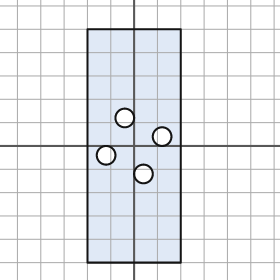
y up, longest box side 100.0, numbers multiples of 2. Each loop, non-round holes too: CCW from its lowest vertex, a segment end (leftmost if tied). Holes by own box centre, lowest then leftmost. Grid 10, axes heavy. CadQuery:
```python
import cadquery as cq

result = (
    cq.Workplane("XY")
    .moveTo(-20.0, -50.0)
    .lineTo(20.0, -50.0)
    .lineTo(20.0, 50.0)
    .lineTo(-20.0, 50.0)
    .close()
    .moveTo(4.0, -12.0)
    .circle(4.0)
    .moveTo(-12.0, -4.0)
    .circle(4.0)
    .moveTo(12.0, 4.0)
    .circle(4.0)
    .moveTo(-4.0, 12.0)
    .circle(4.0)
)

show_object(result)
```